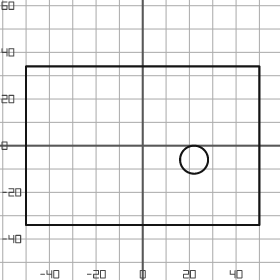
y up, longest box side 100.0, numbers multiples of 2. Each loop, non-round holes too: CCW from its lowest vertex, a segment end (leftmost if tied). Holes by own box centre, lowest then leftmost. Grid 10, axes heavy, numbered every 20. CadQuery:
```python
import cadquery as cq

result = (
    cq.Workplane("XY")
    .moveTo(-50.0, -34.0)
    .lineTo(50.0, -34.0)
    .lineTo(50.0, 34.0)
    .lineTo(-50.0, 34.0)
    .close()
    .moveTo(22.0, -6.0)
    .circle(6.0)
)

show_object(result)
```